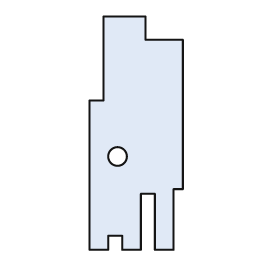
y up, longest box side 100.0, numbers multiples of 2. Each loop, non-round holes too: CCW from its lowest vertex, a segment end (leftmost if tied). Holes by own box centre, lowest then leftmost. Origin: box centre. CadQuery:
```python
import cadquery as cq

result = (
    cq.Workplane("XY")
    .moveTo(-20.0, -50.0)
    .lineTo(-12.0, -50.0)
    .lineTo(-12.0, -44.0)
    .lineTo(-6.0, -44.0)
    .lineTo(-6.0, -50.0)
    .lineTo(2.0, -50.0)
    .lineTo(2.0, -26.0)
    .lineTo(8.0, -26.0)
    .lineTo(8.0, -50.0)
    .lineTo(16.0, -50.0)
    .lineTo(16.0, -24.0)
    .lineTo(20.0, -24.0)
    .lineTo(20.0, 40.0)
    .lineTo(4.0, 40.0)
    .lineTo(4.0, 50.0)
    .lineTo(-14.0, 50.0)
    .lineTo(-14.0, 14.0)
    .lineTo(-20.0, 14.0)
    .close()
    .moveTo(-8.0, -10.0)
    .circle(4.0)
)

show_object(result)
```